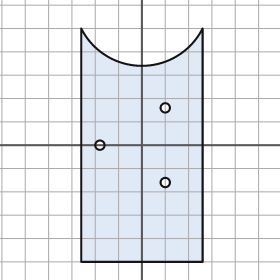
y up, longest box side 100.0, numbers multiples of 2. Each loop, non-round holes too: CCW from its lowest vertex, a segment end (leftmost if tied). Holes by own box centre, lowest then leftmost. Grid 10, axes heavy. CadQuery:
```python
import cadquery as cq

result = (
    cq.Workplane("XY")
    .moveTo(-26.0, -50.0)
    .lineTo(26.0, -50.0)
    .lineTo(26.0, 50.0)
    .threePointArc((0.0, 34.0), (-26.0, 50.0))
    .close()
    .moveTo(10.0, -16.0)
    .circle(2.0)
    .moveTo(-18.0, 0.0)
    .circle(2.0)
    .moveTo(10.0, 16.0)
    .circle(2.0)
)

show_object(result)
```